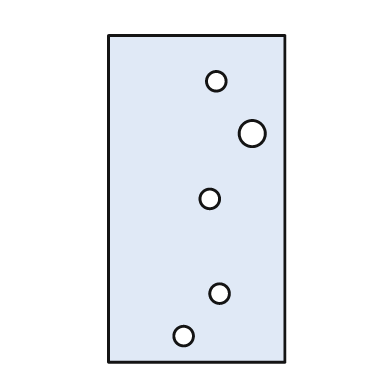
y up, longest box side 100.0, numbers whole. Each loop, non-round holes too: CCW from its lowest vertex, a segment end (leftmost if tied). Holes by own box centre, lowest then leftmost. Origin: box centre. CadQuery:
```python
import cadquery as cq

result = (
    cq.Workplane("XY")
    .moveTo(-27.0, -50.0)
    .lineTo(27.0, -50.0)
    .lineTo(27.0, 50.0)
    .lineTo(-27.0, 50.0)
    .close()
    .moveTo(-4.0, -42.0)
    .circle(3.0)
    .moveTo(7.0, -29.0)
    .circle(3.0)
    .moveTo(4.0, 0.0)
    .circle(3.0)
    .moveTo(17.0, 20.0)
    .circle(4.0)
    .moveTo(6.0, 36.0)
    .circle(3.0)
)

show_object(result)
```